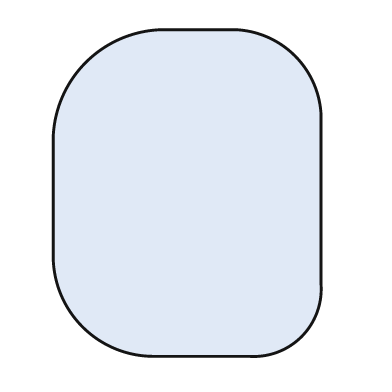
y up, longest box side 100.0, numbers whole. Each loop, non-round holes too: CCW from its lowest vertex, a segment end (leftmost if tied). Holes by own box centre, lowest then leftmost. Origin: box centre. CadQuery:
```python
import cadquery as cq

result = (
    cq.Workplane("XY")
    .moveTo(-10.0, -50.0)
    .lineTo(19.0, -50.0)
    .threePointArc((35.0, -44.0), (41.0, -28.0))
    .lineTo(41.0, 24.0)
    .threePointArc((33.0, 42.0), (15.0, 50.0))
    .lineTo(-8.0, 50.0)
    .threePointArc((-31.0, 40.0), (-41.0, 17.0))
    .lineTo(-41.0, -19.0)
    .threePointArc((-32.0, -41.0), (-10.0, -50.0))
    .close()
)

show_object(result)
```